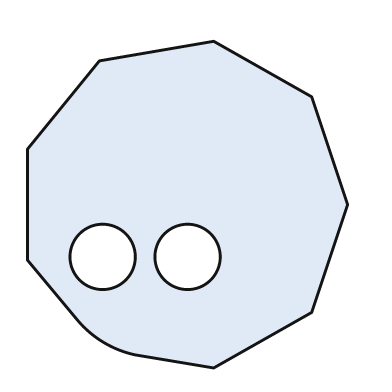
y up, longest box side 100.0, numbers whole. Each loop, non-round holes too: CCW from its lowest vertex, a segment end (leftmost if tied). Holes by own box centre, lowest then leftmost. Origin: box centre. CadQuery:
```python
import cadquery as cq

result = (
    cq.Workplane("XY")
    .moveTo(8.0, -50.0)
    .lineTo(38.0, -33.0)
    .lineTo(49.0, 0.0)
    .lineTo(38.0, 33.0)
    .lineTo(8.0, 50.0)
    .lineTo(-27.0, 44.0)
    .lineTo(-49.0, 17.0)
    .lineTo(-49.0, -17.0)
    .lineTo(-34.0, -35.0)
    .threePointArc((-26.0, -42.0), (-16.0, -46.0))
    .close()
    .moveTo(-26.0, -16.0)
    .circle(10.0)
    .moveTo(0.0, -16.0)
    .circle(10.0)
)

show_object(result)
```